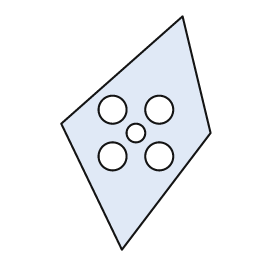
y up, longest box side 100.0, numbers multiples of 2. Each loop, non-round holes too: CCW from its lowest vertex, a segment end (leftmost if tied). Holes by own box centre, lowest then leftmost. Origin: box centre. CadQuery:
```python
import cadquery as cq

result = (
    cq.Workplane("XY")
    .moveTo(-6.0, -50.0)
    .lineTo(32.0, 0.0)
    .lineTo(20.0, 50.0)
    .lineTo(-32.0, 4.0)
    .close()
    .moveTo(-10.0, -10.0)
    .circle(6.0)
    .moveTo(10.0, -10.0)
    .circle(6.0)
    .moveTo(0.0, 0.0)
    .circle(4.0)
    .moveTo(-10.0, 10.0)
    .circle(6.0)
    .moveTo(10.0, 10.0)
    .circle(6.0)
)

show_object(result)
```